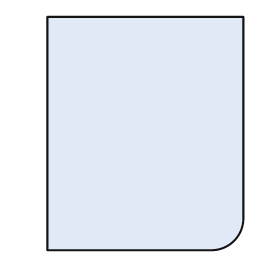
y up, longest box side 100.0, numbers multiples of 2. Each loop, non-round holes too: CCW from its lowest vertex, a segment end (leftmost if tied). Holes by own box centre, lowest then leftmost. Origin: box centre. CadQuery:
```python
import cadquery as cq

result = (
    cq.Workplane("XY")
    .moveTo(-42.0, -50.0)
    .lineTo(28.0, -50.0)
    .threePointArc((38.0, -46.0), (42.0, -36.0))
    .lineTo(42.0, 50.0)
    .lineTo(-42.0, 50.0)
    .close()
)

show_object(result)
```